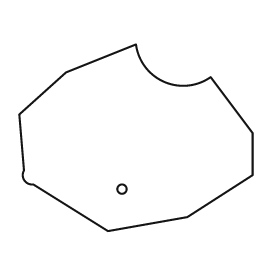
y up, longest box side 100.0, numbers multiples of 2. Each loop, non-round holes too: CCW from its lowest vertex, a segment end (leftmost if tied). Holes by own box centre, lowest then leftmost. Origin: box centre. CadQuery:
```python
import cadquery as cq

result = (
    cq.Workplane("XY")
    .moveTo(-12.0, -40.0)
    .lineTo(22.0, -34.0)
    .lineTo(50.0, -16.0)
    .lineTo(50.0, 2.0)
    .lineTo(32.0, 26.0)
    .threePointArc((12.0, 24.0), (0.0, 40.0))
    .lineTo(-30.0, 28.0)
    .lineTo(-50.0, 10.0)
    .lineTo(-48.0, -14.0)
    .threePointArc((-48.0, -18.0), (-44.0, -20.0))
    .close()
    .moveTo(-6.0, -22.0)
    .circle(2.0)
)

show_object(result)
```